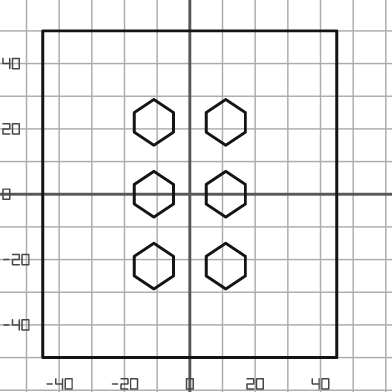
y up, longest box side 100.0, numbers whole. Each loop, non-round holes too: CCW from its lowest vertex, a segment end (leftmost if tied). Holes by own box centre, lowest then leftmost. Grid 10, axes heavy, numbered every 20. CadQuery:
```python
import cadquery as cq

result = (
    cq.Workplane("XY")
    .moveTo(-45.0, -50.0)
    .lineTo(45.0, -50.0)
    .lineTo(45.0, 50.0)
    .lineTo(-45.0, 50.0)
    .close()
    .moveTo(-11.0, -29.0)
    .lineTo(-5.0, -25.0)
    .lineTo(-5.0, -19.0)
    .lineTo(-11.0, -15.0)
    .lineTo(-17.0, -19.0)
    .lineTo(-17.0, -25.0)
    .close()
    .moveTo(11.0, -29.0)
    .lineTo(17.0, -25.0)
    .lineTo(17.0, -19.0)
    .lineTo(11.0, -15.0)
    .lineTo(5.0, -19.0)
    .lineTo(5.0, -25.0)
    .close()
    .moveTo(-11.0, -7.0)
    .lineTo(-5.0, -3.0)
    .lineTo(-5.0, 3.0)
    .lineTo(-11.0, 7.0)
    .lineTo(-17.0, 3.0)
    .lineTo(-17.0, -3.0)
    .close()
    .moveTo(11.0, -7.0)
    .lineTo(17.0, -3.0)
    .lineTo(17.0, 3.0)
    .lineTo(11.0, 7.0)
    .lineTo(5.0, 3.0)
    .lineTo(5.0, -3.0)
    .close()
    .moveTo(-11.0, 15.0)
    .lineTo(-5.0, 19.0)
    .lineTo(-5.0, 25.0)
    .lineTo(-11.0, 29.0)
    .lineTo(-17.0, 25.0)
    .lineTo(-17.0, 19.0)
    .close()
    .moveTo(11.0, 15.0)
    .lineTo(17.0, 19.0)
    .lineTo(17.0, 25.0)
    .lineTo(11.0, 29.0)
    .lineTo(5.0, 25.0)
    .lineTo(5.0, 19.0)
    .close()
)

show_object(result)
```